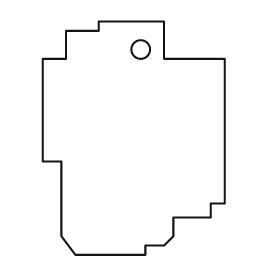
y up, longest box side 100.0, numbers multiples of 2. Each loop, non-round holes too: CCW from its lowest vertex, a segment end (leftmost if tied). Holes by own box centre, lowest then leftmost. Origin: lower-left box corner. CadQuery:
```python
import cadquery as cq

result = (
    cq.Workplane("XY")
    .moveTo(14.0, 0.0)
    .lineTo(44.0, 0.0)
    .lineTo(44.0, 4.0)
    .lineTo(52.0, 4.0)
    .lineTo(56.0, 8.0)
    .lineTo(56.0, 16.0)
    .lineTo(72.0, 16.0)
    .lineTo(72.0, 22.0)
    .lineTo(78.0, 22.0)
    .lineTo(78.0, 84.0)
    .lineTo(52.0, 84.0)
    .lineTo(52.0, 100.0)
    .lineTo(24.0, 100.0)
    .lineTo(24.0, 96.0)
    .lineTo(10.0, 96.0)
    .lineTo(10.0, 84.0)
    .lineTo(0.0, 84.0)
    .lineTo(0.0, 40.0)
    .lineTo(8.0, 40.0)
    .lineTo(8.0, 8.0)
    .close()
    .moveTo(42.0, 88.0)
    .circle(4.0)
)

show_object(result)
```